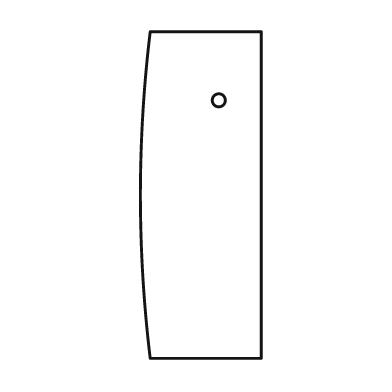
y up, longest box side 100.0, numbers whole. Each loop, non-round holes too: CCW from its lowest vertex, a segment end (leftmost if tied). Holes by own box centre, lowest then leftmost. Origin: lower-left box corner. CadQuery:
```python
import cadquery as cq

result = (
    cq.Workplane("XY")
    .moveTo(3.0, 0.0)
    .lineTo(37.0, 0.0)
    .lineTo(37.0, 100.0)
    .lineTo(3.0, 100.0)
    .threePointArc((0.0, 50.0), (3.0, 0.0))
    .close()
    .moveTo(24.0, 79.0)
    .circle(2.0)
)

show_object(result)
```